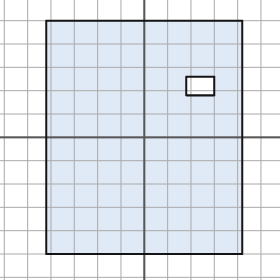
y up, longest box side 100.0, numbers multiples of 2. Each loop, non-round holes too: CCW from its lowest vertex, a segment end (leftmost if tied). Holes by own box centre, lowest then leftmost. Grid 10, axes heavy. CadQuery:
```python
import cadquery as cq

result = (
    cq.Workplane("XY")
    .moveTo(-42.0, -50.0)
    .lineTo(42.0, -50.0)
    .lineTo(42.0, 50.0)
    .lineTo(-42.0, 50.0)
    .close()
    .moveTo(18.0, 18.0)
    .lineTo(30.0, 18.0)
    .lineTo(30.0, 26.0)
    .lineTo(18.0, 26.0)
    .close()
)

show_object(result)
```